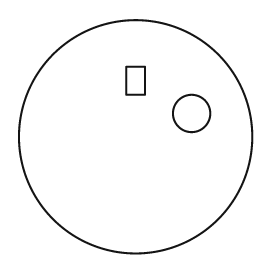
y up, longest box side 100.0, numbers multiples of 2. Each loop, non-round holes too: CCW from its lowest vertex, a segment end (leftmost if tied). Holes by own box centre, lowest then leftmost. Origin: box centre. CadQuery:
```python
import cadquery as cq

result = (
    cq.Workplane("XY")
    .moveTo(0.0, 0.0)
    .circle(50.0)
    .moveTo(24.0, 10.0)
    .circle(8.0)
    .moveTo(-4.0, 18.0)
    .lineTo(4.0, 18.0)
    .lineTo(4.0, 30.0)
    .lineTo(-4.0, 30.0)
    .close()
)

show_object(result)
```